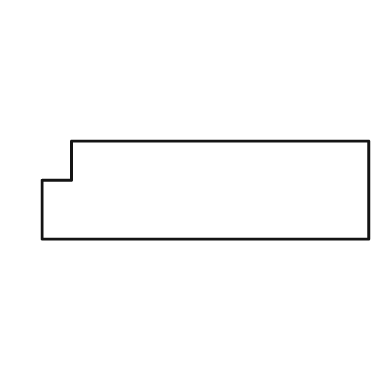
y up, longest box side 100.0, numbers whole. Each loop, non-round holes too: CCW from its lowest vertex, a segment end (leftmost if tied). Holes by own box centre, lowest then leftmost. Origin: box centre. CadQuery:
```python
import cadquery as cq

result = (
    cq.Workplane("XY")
    .moveTo(-50.0, -15.0)
    .lineTo(50.0, -15.0)
    .lineTo(50.0, 15.0)
    .lineTo(-41.0, 15.0)
    .lineTo(-41.0, 3.0)
    .lineTo(-50.0, 3.0)
    .close()
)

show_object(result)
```